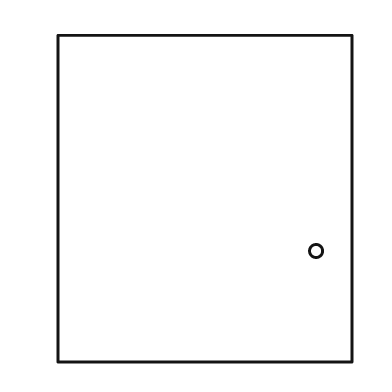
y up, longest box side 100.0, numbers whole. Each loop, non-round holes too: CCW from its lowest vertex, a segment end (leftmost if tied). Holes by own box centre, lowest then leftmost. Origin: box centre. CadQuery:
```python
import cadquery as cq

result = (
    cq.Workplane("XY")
    .moveTo(-45.0, -50.0)
    .lineTo(45.0, -50.0)
    .lineTo(45.0, 50.0)
    .lineTo(-45.0, 50.0)
    .close()
    .moveTo(34.0, -16.0)
    .circle(2.0)
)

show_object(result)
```